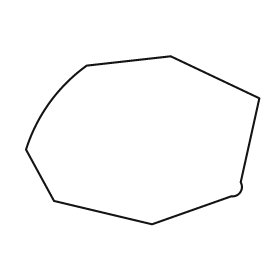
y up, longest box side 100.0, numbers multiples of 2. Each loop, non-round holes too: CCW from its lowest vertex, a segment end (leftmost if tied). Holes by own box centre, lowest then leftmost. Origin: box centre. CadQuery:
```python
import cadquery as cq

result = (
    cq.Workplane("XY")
    .moveTo(4.0, -36.0)
    .lineTo(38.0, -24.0)
    .threePointArc((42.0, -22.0), (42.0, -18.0))
    .lineTo(50.0, 18.0)
    .lineTo(12.0, 36.0)
    .lineTo(-24.0, 32.0)
    .threePointArc((-40.0, 16.0), (-50.0, -4.0))
    .lineTo(-38.0, -26.0)
    .close()
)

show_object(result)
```